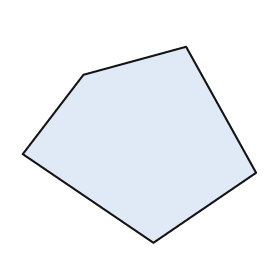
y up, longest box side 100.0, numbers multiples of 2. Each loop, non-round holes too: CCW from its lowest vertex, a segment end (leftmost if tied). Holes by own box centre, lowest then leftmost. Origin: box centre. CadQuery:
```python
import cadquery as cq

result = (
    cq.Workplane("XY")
    .moveTo(6.0, -42.0)
    .lineTo(50.0, -12.0)
    .lineTo(20.0, 42.0)
    .lineTo(-24.0, 30.0)
    .lineTo(-50.0, -4.0)
    .close()
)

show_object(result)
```